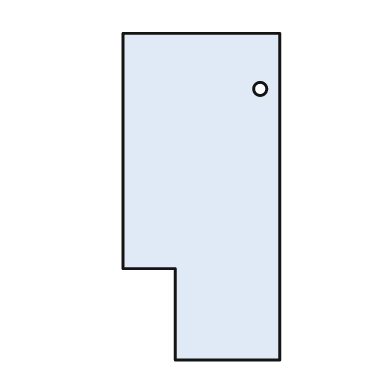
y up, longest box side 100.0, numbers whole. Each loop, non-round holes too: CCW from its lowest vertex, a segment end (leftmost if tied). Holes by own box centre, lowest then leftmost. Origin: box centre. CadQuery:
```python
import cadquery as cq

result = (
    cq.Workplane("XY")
    .moveTo(-8.0, -50.0)
    .lineTo(24.0, -50.0)
    .lineTo(24.0, 50.0)
    .lineTo(-24.0, 50.0)
    .lineTo(-24.0, -22.0)
    .lineTo(-8.0, -22.0)
    .close()
    .moveTo(18.0, 33.0)
    .circle(2.0)
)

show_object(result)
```